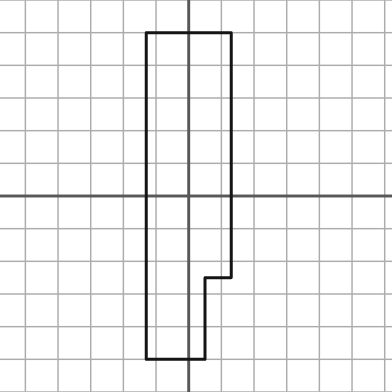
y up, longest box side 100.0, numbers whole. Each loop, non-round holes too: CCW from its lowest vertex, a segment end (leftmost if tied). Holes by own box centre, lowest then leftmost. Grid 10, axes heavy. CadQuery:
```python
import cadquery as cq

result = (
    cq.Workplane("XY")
    .moveTo(-13.0, -50.0)
    .lineTo(5.0, -50.0)
    .lineTo(5.0, -25.0)
    .lineTo(13.0, -25.0)
    .lineTo(13.0, 50.0)
    .lineTo(-13.0, 50.0)
    .close()
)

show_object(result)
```